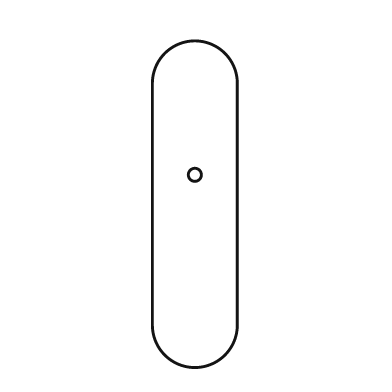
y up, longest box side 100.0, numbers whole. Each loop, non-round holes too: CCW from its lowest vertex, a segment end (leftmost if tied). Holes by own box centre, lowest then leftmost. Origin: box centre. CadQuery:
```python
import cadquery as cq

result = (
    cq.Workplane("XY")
    .moveTo(-13.0, -37.0)
    .threePointArc((0.0, -50.0), (13.0, -37.0))
    .lineTo(13.0, 37.0)
    .threePointArc((0.0, 50.0), (-13.0, 37.0))
    .close()
    .moveTo(0.0, 9.0)
    .circle(2.0)
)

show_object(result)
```